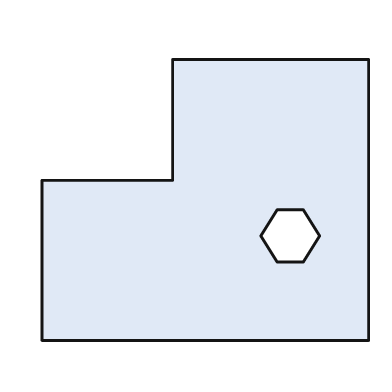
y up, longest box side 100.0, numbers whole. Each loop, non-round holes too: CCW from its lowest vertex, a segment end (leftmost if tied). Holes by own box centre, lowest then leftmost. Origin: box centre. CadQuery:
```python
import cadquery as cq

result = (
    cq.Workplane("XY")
    .moveTo(-50.0, -43.0)
    .lineTo(50.0, -43.0)
    .lineTo(50.0, 43.0)
    .lineTo(-10.0, 43.0)
    .lineTo(-10.0, 6.0)
    .lineTo(-50.0, 6.0)
    .close()
    .moveTo(22.0, -19.0)
    .lineTo(30.0, -19.0)
    .lineTo(35.0, -11.0)
    .lineTo(30.0, -3.0)
    .lineTo(22.0, -3.0)
    .lineTo(17.0, -11.0)
    .close()
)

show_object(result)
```